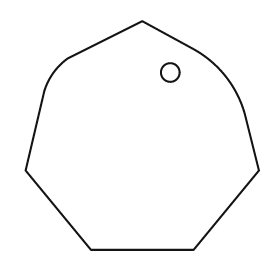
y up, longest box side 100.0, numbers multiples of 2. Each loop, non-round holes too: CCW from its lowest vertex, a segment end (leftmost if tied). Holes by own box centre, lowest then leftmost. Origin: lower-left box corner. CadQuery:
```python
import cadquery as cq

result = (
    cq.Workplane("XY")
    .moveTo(28.0, 0.0)
    .lineTo(72.0, 0.0)
    .lineTo(100.0, 34.0)
    .lineTo(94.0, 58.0)
    .threePointArc((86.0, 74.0), (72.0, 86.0))
    .lineTo(50.0, 98.0)
    .lineTo(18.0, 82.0)
    .threePointArc((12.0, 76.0), (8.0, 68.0))
    .lineTo(0.0, 34.0)
    .close()
    .moveTo(62.0, 76.0)
    .circle(4.0)
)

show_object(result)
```